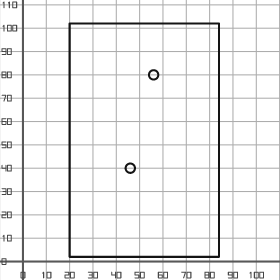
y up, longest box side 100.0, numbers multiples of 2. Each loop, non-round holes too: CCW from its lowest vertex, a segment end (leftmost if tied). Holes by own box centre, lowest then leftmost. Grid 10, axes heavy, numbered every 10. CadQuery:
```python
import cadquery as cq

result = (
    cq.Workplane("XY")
    .moveTo(20.0, 2.0)
    .lineTo(84.0, 2.0)
    .lineTo(84.0, 102.0)
    .lineTo(20.0, 102.0)
    .close()
    .moveTo(46.0, 40.0)
    .circle(2.0)
    .moveTo(56.0, 80.0)
    .circle(2.0)
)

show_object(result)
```